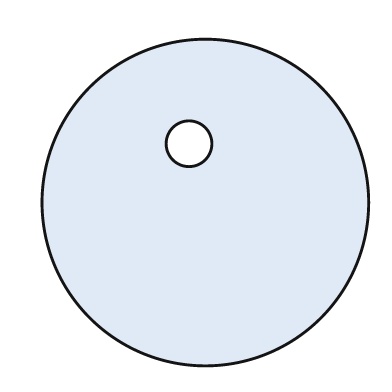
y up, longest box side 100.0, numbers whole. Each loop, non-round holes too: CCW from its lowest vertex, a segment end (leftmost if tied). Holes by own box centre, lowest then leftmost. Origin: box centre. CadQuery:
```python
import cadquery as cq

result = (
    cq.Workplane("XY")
    .moveTo(0.0, 0.0)
    .circle(50.0)
    .moveTo(-5.0, 18.0)
    .circle(7.0)
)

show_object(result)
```